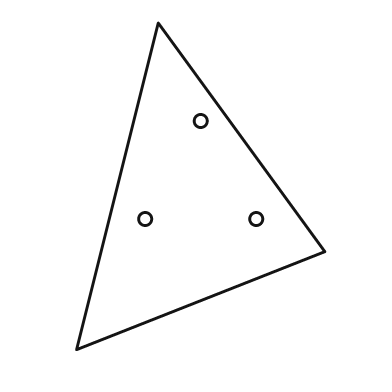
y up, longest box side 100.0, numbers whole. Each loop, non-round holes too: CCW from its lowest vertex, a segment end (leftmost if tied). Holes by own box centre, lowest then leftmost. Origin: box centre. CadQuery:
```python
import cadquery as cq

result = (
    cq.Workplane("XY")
    .moveTo(-38.0, -50.0)
    .lineTo(38.0, -20.0)
    .lineTo(-13.0, 50.0)
    .close()
    .moveTo(-17.0, -10.0)
    .circle(2.0)
    .moveTo(17.0, -10.0)
    .circle(2.0)
    .moveTo(0.0, 20.0)
    .circle(2.0)
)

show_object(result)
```